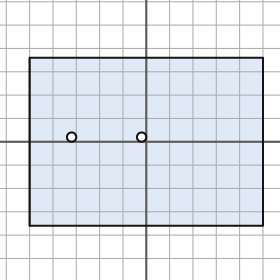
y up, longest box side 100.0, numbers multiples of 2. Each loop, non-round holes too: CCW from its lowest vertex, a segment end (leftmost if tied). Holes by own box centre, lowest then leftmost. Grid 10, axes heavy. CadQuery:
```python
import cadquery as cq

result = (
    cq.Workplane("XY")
    .moveTo(-50.0, -36.0)
    .lineTo(50.0, -36.0)
    .lineTo(50.0, 36.0)
    .lineTo(-50.0, 36.0)
    .close()
    .moveTo(-32.0, 2.0)
    .circle(2.0)
    .moveTo(-2.0, 2.0)
    .circle(2.0)
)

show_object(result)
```